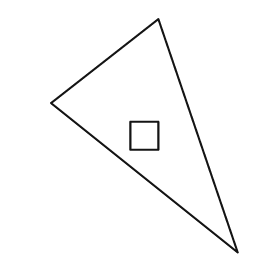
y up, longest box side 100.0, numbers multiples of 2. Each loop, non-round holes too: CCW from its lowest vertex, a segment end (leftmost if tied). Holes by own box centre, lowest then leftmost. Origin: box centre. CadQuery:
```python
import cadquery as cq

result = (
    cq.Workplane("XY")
    .moveTo(40.0, -50.0)
    .lineTo(6.0, 50.0)
    .lineTo(-40.0, 14.0)
    .close()
    .moveTo(-6.0, -6.0)
    .lineTo(6.0, -6.0)
    .lineTo(6.0, 6.0)
    .lineTo(-6.0, 6.0)
    .close()
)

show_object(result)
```